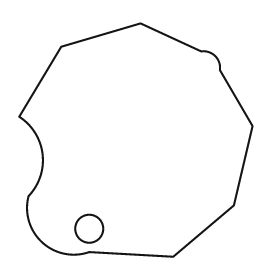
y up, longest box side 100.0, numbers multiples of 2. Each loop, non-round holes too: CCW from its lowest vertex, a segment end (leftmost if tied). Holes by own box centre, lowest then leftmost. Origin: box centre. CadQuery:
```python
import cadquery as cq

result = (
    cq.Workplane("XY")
    .moveTo(16.0, -50.0)
    .lineTo(42.0, -28.0)
    .lineTo(50.0, 6.0)
    .lineTo(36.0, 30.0)
    .threePointArc((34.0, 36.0), (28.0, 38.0))
    .lineTo(2.0, 50.0)
    .lineTo(-32.0, 40.0)
    .lineTo(-50.0, 10.0)
    .threePointArc((-40.0, -6.0), (-46.0, -24.0))
    .threePointArc((-40.0, -44.0), (-20.0, -48.0))
    .close()
    .moveTo(-20.0, -38.0)
    .circle(6.0)
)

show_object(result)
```